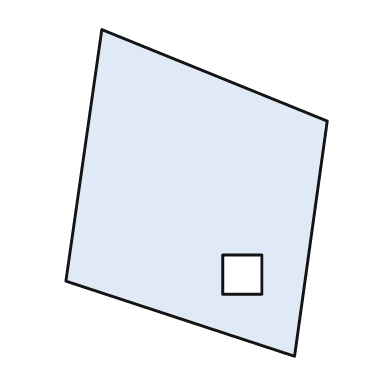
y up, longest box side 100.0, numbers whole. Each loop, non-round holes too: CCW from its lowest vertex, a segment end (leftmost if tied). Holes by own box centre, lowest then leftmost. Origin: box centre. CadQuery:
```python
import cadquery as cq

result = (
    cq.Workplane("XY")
    .moveTo(30.0, -50.0)
    .lineTo(40.0, 22.0)
    .lineTo(-29.0, 50.0)
    .lineTo(-40.0, -27.0)
    .close()
    .moveTo(8.0, -31.0)
    .lineTo(20.0, -31.0)
    .lineTo(20.0, -19.0)
    .lineTo(8.0, -19.0)
    .close()
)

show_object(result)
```